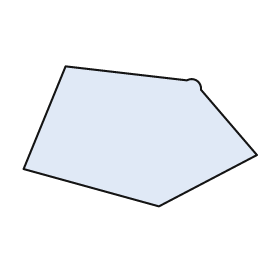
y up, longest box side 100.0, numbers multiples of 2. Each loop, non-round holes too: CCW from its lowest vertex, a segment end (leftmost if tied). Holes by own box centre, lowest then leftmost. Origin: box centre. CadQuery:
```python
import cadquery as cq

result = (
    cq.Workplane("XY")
    .moveTo(8.0, -30.0)
    .lineTo(50.0, -8.0)
    .lineTo(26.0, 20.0)
    .threePointArc((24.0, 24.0), (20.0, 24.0))
    .lineTo(-32.0, 30.0)
    .lineTo(-50.0, -14.0)
    .close()
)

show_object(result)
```